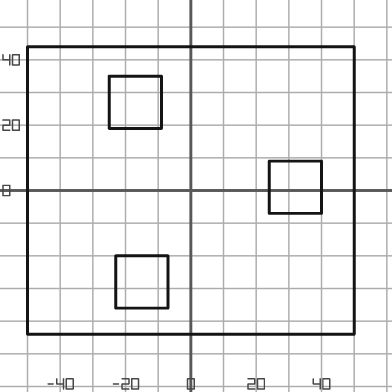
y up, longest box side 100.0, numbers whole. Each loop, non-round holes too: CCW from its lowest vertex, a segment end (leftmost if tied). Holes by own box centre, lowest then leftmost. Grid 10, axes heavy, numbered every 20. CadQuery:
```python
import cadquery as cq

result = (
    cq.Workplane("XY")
    .moveTo(-50.0, -44.0)
    .lineTo(50.0, -44.0)
    .lineTo(50.0, 44.0)
    .lineTo(-50.0, 44.0)
    .close()
    .moveTo(-23.0, -36.0)
    .lineTo(-7.0, -36.0)
    .lineTo(-7.0, -20.0)
    .lineTo(-23.0, -20.0)
    .close()
    .moveTo(24.0, -7.0)
    .lineTo(40.0, -7.0)
    .lineTo(40.0, 9.0)
    .lineTo(24.0, 9.0)
    .close()
    .moveTo(-25.0, 19.0)
    .lineTo(-9.0, 19.0)
    .lineTo(-9.0, 35.0)
    .lineTo(-25.0, 35.0)
    .close()
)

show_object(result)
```